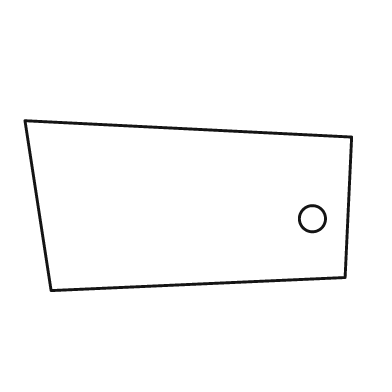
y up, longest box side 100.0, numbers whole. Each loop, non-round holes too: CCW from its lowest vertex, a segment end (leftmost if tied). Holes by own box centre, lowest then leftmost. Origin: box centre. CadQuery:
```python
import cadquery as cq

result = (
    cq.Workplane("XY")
    .moveTo(-42.0, -26.0)
    .lineTo(48.0, -22.0)
    .lineTo(50.0, 21.0)
    .lineTo(-50.0, 26.0)
    .close()
    .moveTo(38.0, -4.0)
    .circle(4.0)
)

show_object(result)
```